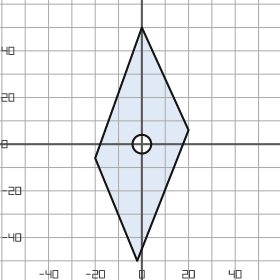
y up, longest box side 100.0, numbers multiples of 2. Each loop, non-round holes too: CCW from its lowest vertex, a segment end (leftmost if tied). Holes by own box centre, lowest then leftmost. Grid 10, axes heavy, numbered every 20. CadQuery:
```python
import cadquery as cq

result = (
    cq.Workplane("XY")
    .moveTo(-2.0, -50.0)
    .lineTo(20.0, 6.0)
    .lineTo(0.0, 50.0)
    .lineTo(-20.0, -6.0)
    .close()
    .moveTo(0.0, 0.0)
    .circle(4.0)
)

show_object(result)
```